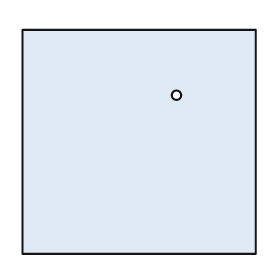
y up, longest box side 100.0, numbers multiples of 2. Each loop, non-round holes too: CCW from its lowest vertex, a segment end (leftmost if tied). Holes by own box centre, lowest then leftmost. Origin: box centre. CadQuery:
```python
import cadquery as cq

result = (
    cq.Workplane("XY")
    .moveTo(-50.0, -48.0)
    .lineTo(50.0, -48.0)
    .lineTo(50.0, 48.0)
    .lineTo(-50.0, 48.0)
    .close()
    .moveTo(16.0, 20.0)
    .circle(2.0)
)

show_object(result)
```